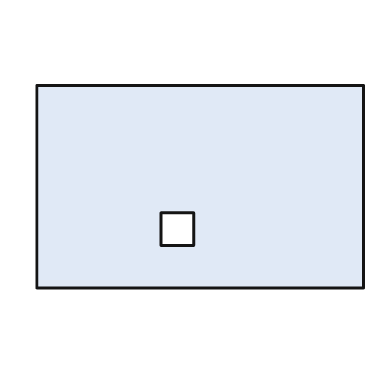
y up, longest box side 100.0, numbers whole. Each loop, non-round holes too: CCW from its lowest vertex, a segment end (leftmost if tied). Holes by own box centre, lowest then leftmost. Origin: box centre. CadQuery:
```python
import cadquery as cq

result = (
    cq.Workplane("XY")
    .moveTo(-50.0, -31.0)
    .lineTo(50.0, -31.0)
    .lineTo(50.0, 31.0)
    .lineTo(-50.0, 31.0)
    .close()
    .moveTo(-12.0, -18.0)
    .lineTo(-2.0, -18.0)
    .lineTo(-2.0, -8.0)
    .lineTo(-12.0, -8.0)
    .close()
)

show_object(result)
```